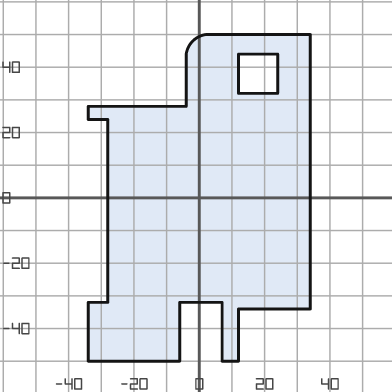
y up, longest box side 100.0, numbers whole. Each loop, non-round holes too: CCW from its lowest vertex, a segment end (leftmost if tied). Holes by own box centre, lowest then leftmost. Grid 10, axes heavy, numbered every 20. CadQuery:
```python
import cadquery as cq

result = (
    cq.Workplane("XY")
    .moveTo(-34.0, -50.0)
    .lineTo(-6.0, -50.0)
    .lineTo(-6.0, -32.0)
    .lineTo(7.0, -32.0)
    .lineTo(7.0, -50.0)
    .lineTo(12.0, -50.0)
    .lineTo(12.0, -34.0)
    .lineTo(34.0, -34.0)
    .lineTo(34.0, 50.0)
    .lineTo(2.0, 50.0)
    .threePointArc((-2.0, 48.0), (-4.0, 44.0))
    .lineTo(-4.0, 28.0)
    .lineTo(-34.0, 28.0)
    .lineTo(-34.0, 24.0)
    .lineTo(-28.0, 24.0)
    .lineTo(-28.0, -32.0)
    .lineTo(-34.0, -32.0)
    .close()
    .moveTo(12.0, 32.0)
    .lineTo(24.0, 32.0)
    .lineTo(24.0, 44.0)
    .lineTo(12.0, 44.0)
    .close()
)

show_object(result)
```